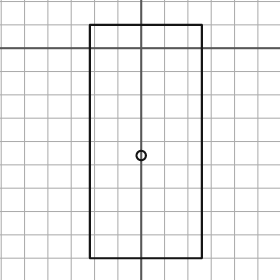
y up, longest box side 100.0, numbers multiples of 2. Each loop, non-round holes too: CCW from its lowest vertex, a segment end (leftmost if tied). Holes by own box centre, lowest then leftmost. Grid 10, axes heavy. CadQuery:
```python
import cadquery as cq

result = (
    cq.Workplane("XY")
    .moveTo(-22.0, -90.0)
    .lineTo(26.0, -90.0)
    .lineTo(26.0, 10.0)
    .lineTo(-22.0, 10.0)
    .close()
    .moveTo(0.0, -46.0)
    .circle(2.0)
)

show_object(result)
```